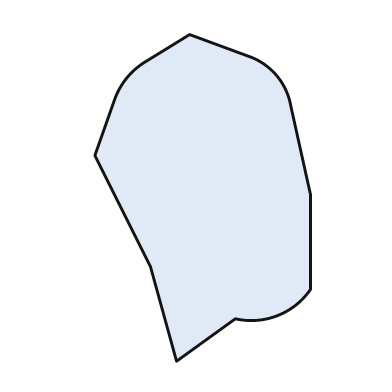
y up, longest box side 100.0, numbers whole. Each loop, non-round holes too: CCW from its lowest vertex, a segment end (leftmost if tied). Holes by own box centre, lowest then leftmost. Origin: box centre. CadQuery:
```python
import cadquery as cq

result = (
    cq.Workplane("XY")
    .moveTo(-8.0, -50.0)
    .lineTo(10.0, -37.0)
    .threePointArc((23.0, -36.0), (33.0, -28.0))
    .lineTo(33.0, 1.0)
    .lineTo(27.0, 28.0)
    .threePointArc((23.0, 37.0), (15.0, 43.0))
    .lineTo(-4.0, 50.0)
    .lineTo(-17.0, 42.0)
    .threePointArc((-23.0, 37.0), (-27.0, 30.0))
    .lineTo(-33.0, 13.0)
    .lineTo(-16.0, -21.0)
    .close()
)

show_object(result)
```